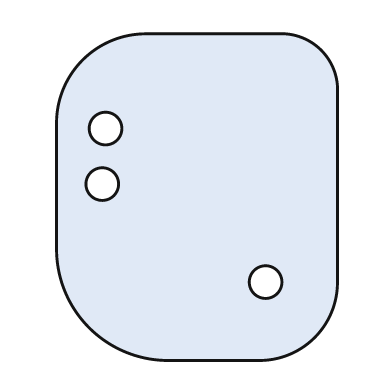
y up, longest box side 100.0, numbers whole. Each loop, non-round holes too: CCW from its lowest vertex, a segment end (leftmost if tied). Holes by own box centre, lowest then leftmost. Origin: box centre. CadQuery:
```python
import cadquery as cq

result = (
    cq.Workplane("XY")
    .moveTo(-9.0, -50.0)
    .lineTo(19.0, -50.0)
    .threePointArc((36.0, -43.0), (43.0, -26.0))
    .lineTo(43.0, 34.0)
    .threePointArc((38.0, 45.0), (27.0, 50.0))
    .lineTo(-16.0, 50.0)
    .threePointArc((-35.0, 42.0), (-43.0, 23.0))
    .lineTo(-43.0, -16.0)
    .threePointArc((-33.0, -40.0), (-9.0, -50.0))
    .close()
    .moveTo(21.0, -26.0)
    .circle(5.0)
    .moveTo(-29.0, 4.0)
    .circle(5.0)
    .moveTo(-28.0, 21.0)
    .circle(5.0)
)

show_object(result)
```